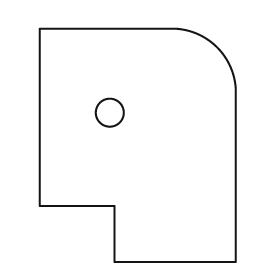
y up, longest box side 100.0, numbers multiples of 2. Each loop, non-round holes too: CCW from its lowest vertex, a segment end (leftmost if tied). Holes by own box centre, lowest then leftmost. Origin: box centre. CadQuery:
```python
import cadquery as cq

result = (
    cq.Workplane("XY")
    .moveTo(-10.0, -50.0)
    .lineTo(42.0, -50.0)
    .lineTo(42.0, 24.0)
    .threePointArc((34.0, 42.0), (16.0, 50.0))
    .lineTo(-42.0, 50.0)
    .lineTo(-42.0, -26.0)
    .lineTo(-10.0, -26.0)
    .close()
    .moveTo(-12.0, 14.0)
    .circle(6.0)
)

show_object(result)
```